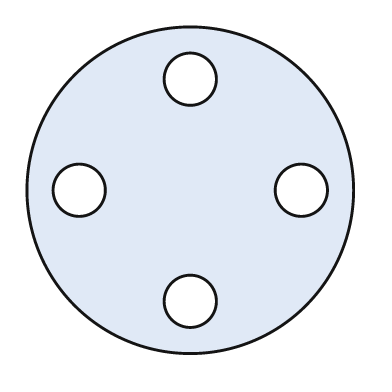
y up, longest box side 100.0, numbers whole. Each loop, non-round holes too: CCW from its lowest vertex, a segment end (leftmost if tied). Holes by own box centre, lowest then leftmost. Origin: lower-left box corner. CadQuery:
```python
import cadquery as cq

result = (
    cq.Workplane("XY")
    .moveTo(50.0, 50.0)
    .circle(50.0)
    .moveTo(50.0, 16.0)
    .circle(8.0)
    .moveTo(16.0, 50.0)
    .circle(8.0)
    .moveTo(84.0, 50.0)
    .circle(8.0)
    .moveTo(50.0, 84.0)
    .circle(8.0)
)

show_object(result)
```